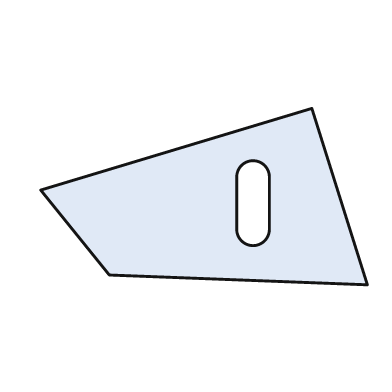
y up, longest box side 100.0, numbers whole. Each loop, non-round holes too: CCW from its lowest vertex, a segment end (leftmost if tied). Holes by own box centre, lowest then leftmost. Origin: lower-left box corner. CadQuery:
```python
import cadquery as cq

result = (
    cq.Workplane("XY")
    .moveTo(100.0, 0.0)
    .lineTo(83.0, 54.0)
    .lineTo(0.0, 29.0)
    .lineTo(21.0, 3.0)
    .close()
    .moveTo(60.0, 17.0)
    .threePointArc((65.0, 12.0), (70.0, 17.0))
    .lineTo(70.0, 33.0)
    .threePointArc((65.0, 38.0), (60.0, 33.0))
    .close()
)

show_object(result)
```